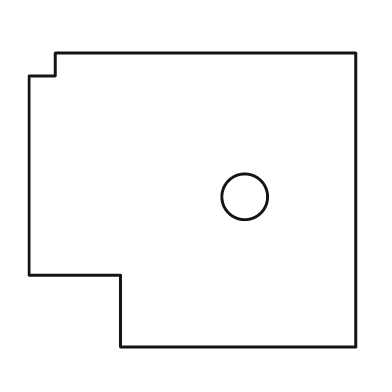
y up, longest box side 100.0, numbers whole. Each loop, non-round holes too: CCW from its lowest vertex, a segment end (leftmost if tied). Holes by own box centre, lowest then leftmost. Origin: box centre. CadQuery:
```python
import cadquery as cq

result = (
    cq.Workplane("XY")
    .moveTo(-22.0, -45.0)
    .lineTo(50.0, -45.0)
    .lineTo(50.0, 45.0)
    .lineTo(-42.0, 45.0)
    .lineTo(-42.0, 38.0)
    .lineTo(-50.0, 38.0)
    .lineTo(-50.0, -23.0)
    .lineTo(-22.0, -23.0)
    .close()
    .moveTo(16.0, 1.0)
    .circle(7.0)
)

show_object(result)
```